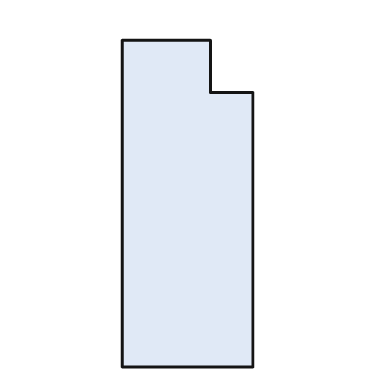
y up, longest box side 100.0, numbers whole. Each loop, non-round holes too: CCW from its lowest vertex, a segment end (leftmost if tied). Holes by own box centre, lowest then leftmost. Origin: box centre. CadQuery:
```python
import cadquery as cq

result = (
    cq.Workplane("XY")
    .moveTo(-20.0, -50.0)
    .lineTo(20.0, -50.0)
    .lineTo(20.0, 34.0)
    .lineTo(7.0, 34.0)
    .lineTo(7.0, 50.0)
    .lineTo(-20.0, 50.0)
    .close()
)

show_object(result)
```